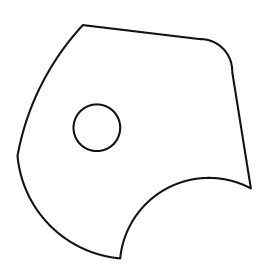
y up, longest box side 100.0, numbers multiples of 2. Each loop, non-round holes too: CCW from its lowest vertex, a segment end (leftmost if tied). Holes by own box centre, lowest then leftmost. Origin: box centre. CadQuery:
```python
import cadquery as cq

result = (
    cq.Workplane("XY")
    .moveTo(-6.0, -50.0)
    .threePointArc((14.0, -20.0), (50.0, -20.0))
    .lineTo(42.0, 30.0)
    .threePointArc((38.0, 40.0), (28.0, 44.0))
    .lineTo(-22.0, 50.0)
    .threePointArc((-40.0, 24.0), (-50.0, -6.0))
    .threePointArc((-36.0, -36.0), (-6.0, -50.0))
    .close()
    .moveTo(-16.0, 6.0)
    .circle(10.0)
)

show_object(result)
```